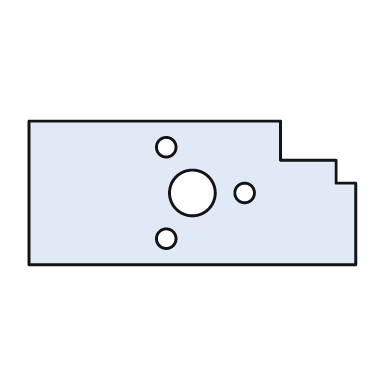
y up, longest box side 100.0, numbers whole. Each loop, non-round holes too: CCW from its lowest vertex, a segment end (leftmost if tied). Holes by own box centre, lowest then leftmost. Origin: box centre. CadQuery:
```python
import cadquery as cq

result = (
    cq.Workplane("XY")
    .moveTo(-50.0, -22.0)
    .lineTo(50.0, -22.0)
    .lineTo(50.0, 3.0)
    .lineTo(44.0, 3.0)
    .lineTo(44.0, 10.0)
    .lineTo(27.0, 10.0)
    .lineTo(27.0, 22.0)
    .lineTo(-50.0, 22.0)
    .close()
    .moveTo(-8.0, -14.0)
    .circle(3.0)
    .moveTo(0.0, 0.0)
    .circle(7.0)
    .moveTo(16.0, 0.0)
    .circle(3.0)
    .moveTo(-8.0, 14.0)
    .circle(3.0)
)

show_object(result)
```